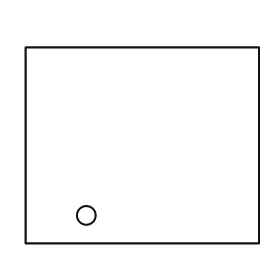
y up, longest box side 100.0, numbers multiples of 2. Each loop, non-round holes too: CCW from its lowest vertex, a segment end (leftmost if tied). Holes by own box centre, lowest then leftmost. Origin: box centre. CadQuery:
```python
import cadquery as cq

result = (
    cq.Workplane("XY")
    .moveTo(-50.0, -42.0)
    .lineTo(50.0, -42.0)
    .lineTo(50.0, 42.0)
    .lineTo(-50.0, 42.0)
    .close()
    .moveTo(-24.0, -30.0)
    .circle(4.0)
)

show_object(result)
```